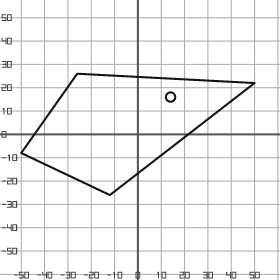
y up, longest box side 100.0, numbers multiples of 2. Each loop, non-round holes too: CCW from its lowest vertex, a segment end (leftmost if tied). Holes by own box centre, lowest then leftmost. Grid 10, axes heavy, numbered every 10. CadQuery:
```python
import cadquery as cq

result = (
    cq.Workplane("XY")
    .moveTo(-12.0, -26.0)
    .lineTo(50.0, 22.0)
    .lineTo(-26.0, 26.0)
    .lineTo(-50.0, -8.0)
    .close()
    .moveTo(14.0, 16.0)
    .circle(2.0)
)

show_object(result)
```